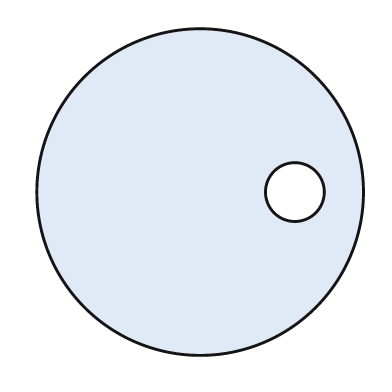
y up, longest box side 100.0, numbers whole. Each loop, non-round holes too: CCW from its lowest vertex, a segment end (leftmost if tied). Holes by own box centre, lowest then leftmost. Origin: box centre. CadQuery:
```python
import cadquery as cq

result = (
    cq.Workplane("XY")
    .moveTo(0.0, 0.0)
    .circle(50.0)
    .moveTo(29.0, 0.0)
    .circle(9.0)
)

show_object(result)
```